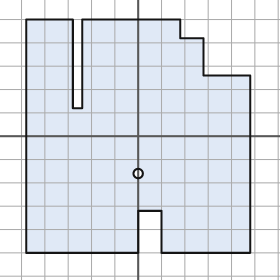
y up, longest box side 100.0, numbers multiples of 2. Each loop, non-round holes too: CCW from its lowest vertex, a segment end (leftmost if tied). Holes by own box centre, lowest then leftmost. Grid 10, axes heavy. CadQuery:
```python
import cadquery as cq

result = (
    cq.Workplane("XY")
    .moveTo(-48.0, -50.0)
    .lineTo(0.0, -50.0)
    .lineTo(0.0, -32.0)
    .lineTo(10.0, -32.0)
    .lineTo(10.0, -50.0)
    .lineTo(48.0, -50.0)
    .lineTo(48.0, 26.0)
    .lineTo(28.0, 26.0)
    .lineTo(28.0, 42.0)
    .lineTo(18.0, 42.0)
    .lineTo(18.0, 50.0)
    .lineTo(-24.0, 50.0)
    .lineTo(-24.0, 12.0)
    .lineTo(-28.0, 12.0)
    .lineTo(-28.0, 50.0)
    .lineTo(-48.0, 50.0)
    .close()
    .moveTo(0.0, -16.0)
    .circle(2.0)
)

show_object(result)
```